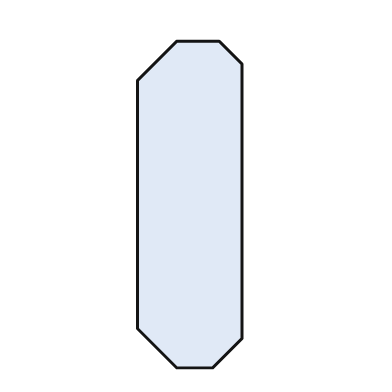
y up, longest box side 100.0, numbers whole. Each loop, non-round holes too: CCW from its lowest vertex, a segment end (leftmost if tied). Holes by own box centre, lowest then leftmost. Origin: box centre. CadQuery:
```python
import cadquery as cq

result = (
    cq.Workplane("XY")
    .moveTo(-4.0, -50.0)
    .lineTo(7.0, -50.0)
    .lineTo(16.0, -41.0)
    .lineTo(16.0, 43.0)
    .lineTo(9.0, 50.0)
    .lineTo(-4.0, 50.0)
    .lineTo(-16.0, 38.0)
    .lineTo(-16.0, -38.0)
    .close()
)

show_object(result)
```